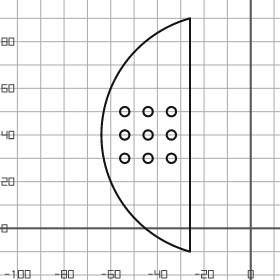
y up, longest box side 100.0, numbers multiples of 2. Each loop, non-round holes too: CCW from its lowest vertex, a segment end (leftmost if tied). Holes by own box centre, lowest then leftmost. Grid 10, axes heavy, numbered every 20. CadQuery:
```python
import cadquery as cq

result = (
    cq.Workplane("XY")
    .moveTo(-26.0, -10.0)
    .lineTo(-26.0, 90.0)
    .threePointArc((-64.0, 40.0), (-26.0, -10.0))
    .close()
    .moveTo(-54.0, 30.0)
    .circle(2.0)
    .moveTo(-44.0, 30.0)
    .circle(2.0)
    .moveTo(-34.0, 30.0)
    .circle(2.0)
    .moveTo(-54.0, 40.0)
    .circle(2.0)
    .moveTo(-44.0, 40.0)
    .circle(2.0)
    .moveTo(-34.0, 40.0)
    .circle(2.0)
    .moveTo(-54.0, 50.0)
    .circle(2.0)
    .moveTo(-44.0, 50.0)
    .circle(2.0)
    .moveTo(-34.0, 50.0)
    .circle(2.0)
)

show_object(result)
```